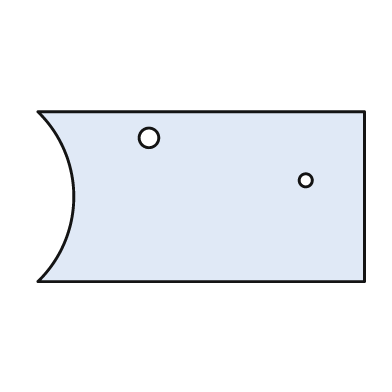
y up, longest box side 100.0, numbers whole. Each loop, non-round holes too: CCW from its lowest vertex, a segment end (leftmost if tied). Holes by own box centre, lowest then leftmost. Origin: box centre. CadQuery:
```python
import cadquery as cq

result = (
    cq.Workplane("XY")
    .moveTo(-50.0, -26.0)
    .lineTo(50.0, -26.0)
    .lineTo(50.0, 26.0)
    .lineTo(-50.0, 26.0)
    .threePointArc((-39.0, 0.0), (-50.0, -26.0))
    .close()
    .moveTo(32.0, 5.0)
    .circle(2.0)
    .moveTo(-16.0, 18.0)
    .circle(3.0)
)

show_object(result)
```